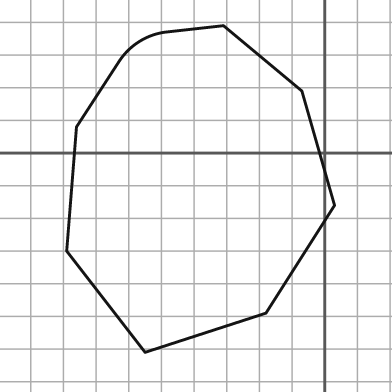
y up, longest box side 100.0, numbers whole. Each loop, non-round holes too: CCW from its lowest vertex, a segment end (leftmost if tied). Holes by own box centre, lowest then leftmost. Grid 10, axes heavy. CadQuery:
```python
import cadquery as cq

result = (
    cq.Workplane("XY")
    .moveTo(-55.0, -61.0)
    .lineTo(-18.0, -49.0)
    .lineTo(3.0, -16.0)
    .lineTo(-7.0, 19.0)
    .lineTo(-31.0, 39.0)
    .lineTo(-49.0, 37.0)
    .threePointArc((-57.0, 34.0), (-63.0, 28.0))
    .lineTo(-76.0, 8.0)
    .lineTo(-79.0, -30.0)
    .close()
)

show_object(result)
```